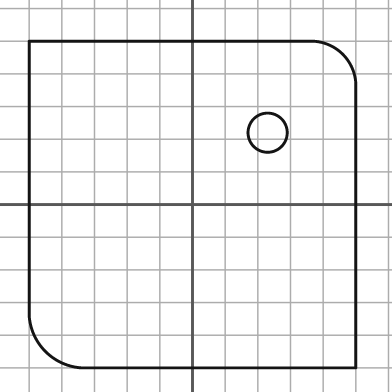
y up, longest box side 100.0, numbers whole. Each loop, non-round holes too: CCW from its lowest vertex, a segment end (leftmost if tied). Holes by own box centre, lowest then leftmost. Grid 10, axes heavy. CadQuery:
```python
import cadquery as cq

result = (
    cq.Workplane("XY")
    .moveTo(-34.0, -50.0)
    .lineTo(50.0, -50.0)
    .lineTo(50.0, 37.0)
    .threePointArc((46.0, 46.0), (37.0, 50.0))
    .lineTo(-50.0, 50.0)
    .lineTo(-50.0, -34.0)
    .threePointArc((-45.0, -45.0), (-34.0, -50.0))
    .close()
    .moveTo(23.0, 22.0)
    .circle(6.0)
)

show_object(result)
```